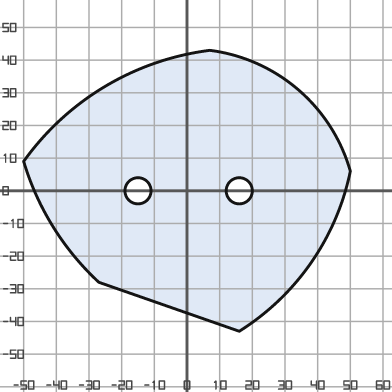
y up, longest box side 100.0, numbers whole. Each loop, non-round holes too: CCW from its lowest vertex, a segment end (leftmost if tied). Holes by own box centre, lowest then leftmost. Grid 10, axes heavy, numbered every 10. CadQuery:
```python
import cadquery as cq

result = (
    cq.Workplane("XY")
    .moveTo(16.0, -43.0)
    .threePointArc((38.0, -22.0), (50.0, 6.0))
    .threePointArc((34.0, 31.0), (7.0, 43.0))
    .threePointArc((-25.0, 32.0), (-50.0, 9.0))
    .threePointArc((-41.0, -11.0), (-27.0, -28.0))
    .close()
    .moveTo(-15.0, 0.0)
    .circle(4.0)
    .moveTo(16.0, 0.0)
    .circle(4.0)
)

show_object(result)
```